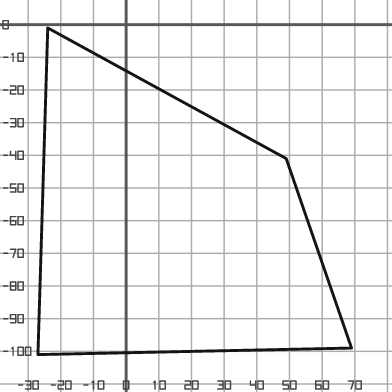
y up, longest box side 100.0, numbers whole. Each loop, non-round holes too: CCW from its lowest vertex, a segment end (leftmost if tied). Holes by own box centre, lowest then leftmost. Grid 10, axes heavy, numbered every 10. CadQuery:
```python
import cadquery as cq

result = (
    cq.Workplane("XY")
    .moveTo(-27.0, -101.0)
    .lineTo(69.0, -99.0)
    .lineTo(49.0, -41.0)
    .lineTo(-24.0, -1.0)
    .close()
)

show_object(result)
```